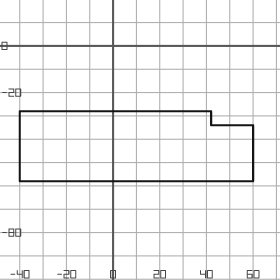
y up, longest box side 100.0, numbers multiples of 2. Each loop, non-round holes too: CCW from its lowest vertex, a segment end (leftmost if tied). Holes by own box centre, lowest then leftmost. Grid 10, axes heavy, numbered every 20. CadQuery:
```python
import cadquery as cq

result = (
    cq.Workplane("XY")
    .moveTo(-40.0, -58.0)
    .lineTo(60.0, -58.0)
    .lineTo(60.0, -34.0)
    .lineTo(42.0, -34.0)
    .lineTo(42.0, -28.0)
    .lineTo(-40.0, -28.0)
    .close()
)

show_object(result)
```